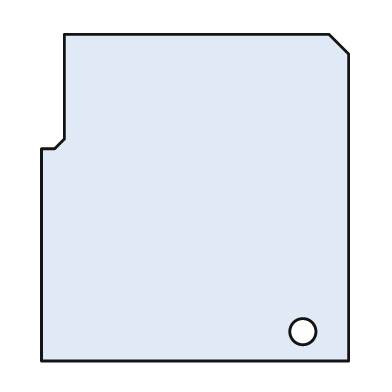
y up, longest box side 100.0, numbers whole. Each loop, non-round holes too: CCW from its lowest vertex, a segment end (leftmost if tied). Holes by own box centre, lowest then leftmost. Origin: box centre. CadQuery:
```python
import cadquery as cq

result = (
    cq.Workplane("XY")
    .moveTo(-47.0, -50.0)
    .lineTo(47.0, -50.0)
    .lineTo(47.0, 44.0)
    .lineTo(41.0, 50.0)
    .lineTo(-40.0, 50.0)
    .lineTo(-40.0, 18.0)
    .lineTo(-43.0, 15.0)
    .lineTo(-47.0, 15.0)
    .close()
    .moveTo(33.0, -41.0)
    .circle(4.0)
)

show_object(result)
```